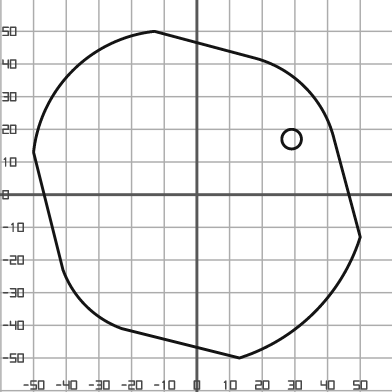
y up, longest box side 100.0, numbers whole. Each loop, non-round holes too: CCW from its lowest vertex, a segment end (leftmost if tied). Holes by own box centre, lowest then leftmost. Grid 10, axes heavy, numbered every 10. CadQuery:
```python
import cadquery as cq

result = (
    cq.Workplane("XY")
    .moveTo(13.0, -50.0)
    .threePointArc((36.0, -36.0), (50.0, -13.0))
    .lineTo(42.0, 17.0)
    .threePointArc((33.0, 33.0), (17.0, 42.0))
    .lineTo(-13.0, 50.0)
    .threePointArc((-38.0, 38.0), (-50.0, 13.0))
    .lineTo(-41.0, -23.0)
    .threePointArc((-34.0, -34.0), (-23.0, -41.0))
    .close()
    .moveTo(29.0, 17.0)
    .circle(3.0)
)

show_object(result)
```